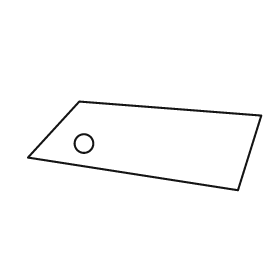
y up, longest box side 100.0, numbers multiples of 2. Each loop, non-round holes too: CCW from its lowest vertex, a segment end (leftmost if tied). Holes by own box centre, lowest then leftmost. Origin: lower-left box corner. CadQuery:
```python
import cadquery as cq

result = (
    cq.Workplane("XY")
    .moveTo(90.0, 0.0)
    .lineTo(100.0, 32.0)
    .lineTo(22.0, 38.0)
    .lineTo(0.0, 14.0)
    .close()
    .moveTo(24.0, 20.0)
    .circle(4.0)
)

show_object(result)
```